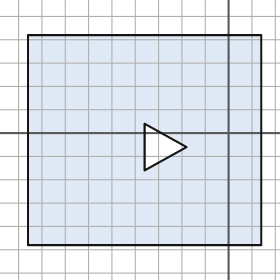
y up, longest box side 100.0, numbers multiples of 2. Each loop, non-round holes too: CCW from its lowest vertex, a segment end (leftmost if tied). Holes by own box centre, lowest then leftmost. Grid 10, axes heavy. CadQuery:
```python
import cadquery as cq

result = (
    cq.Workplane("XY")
    .moveTo(-86.0, -48.0)
    .lineTo(14.0, -48.0)
    .lineTo(14.0, 42.0)
    .lineTo(-86.0, 42.0)
    .close()
    .moveTo(-36.0, -16.0)
    .lineTo(-18.0, -6.0)
    .lineTo(-36.0, 4.0)
    .close()
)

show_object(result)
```